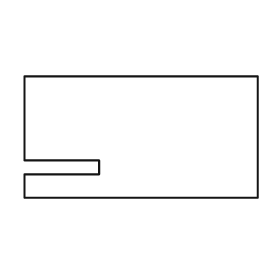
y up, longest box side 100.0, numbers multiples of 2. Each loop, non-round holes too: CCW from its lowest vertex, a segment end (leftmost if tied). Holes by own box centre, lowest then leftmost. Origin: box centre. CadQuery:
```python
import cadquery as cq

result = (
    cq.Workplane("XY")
    .moveTo(-50.0, -26.0)
    .lineTo(50.0, -26.0)
    .lineTo(50.0, 26.0)
    .lineTo(-50.0, 26.0)
    .lineTo(-50.0, -10.0)
    .lineTo(-18.0, -10.0)
    .lineTo(-18.0, -16.0)
    .lineTo(-50.0, -16.0)
    .close()
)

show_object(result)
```